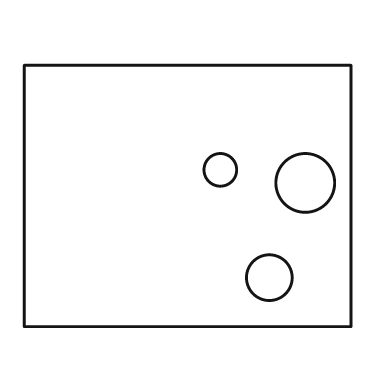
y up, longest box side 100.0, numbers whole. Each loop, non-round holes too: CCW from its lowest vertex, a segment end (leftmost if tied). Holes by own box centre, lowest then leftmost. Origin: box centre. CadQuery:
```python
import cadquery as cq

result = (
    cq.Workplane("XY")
    .moveTo(-50.0, -40.0)
    .lineTo(50.0, -40.0)
    .lineTo(50.0, 40.0)
    .lineTo(-50.0, 40.0)
    .close()
    .moveTo(25.0, -25.0)
    .circle(7.0)
    .moveTo(36.0, 4.0)
    .circle(9.0)
    .moveTo(10.0, 8.0)
    .circle(5.0)
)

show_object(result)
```